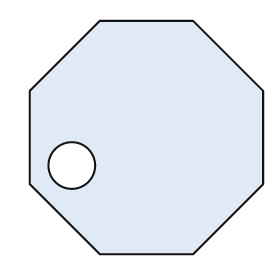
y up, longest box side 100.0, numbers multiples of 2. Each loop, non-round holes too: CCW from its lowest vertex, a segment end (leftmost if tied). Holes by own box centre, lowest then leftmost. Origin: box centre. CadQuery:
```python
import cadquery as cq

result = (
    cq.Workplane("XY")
    .moveTo(-20.0, -50.0)
    .lineTo(20.0, -50.0)
    .lineTo(50.0, -20.0)
    .lineTo(50.0, 20.0)
    .lineTo(20.0, 50.0)
    .lineTo(-20.0, 50.0)
    .lineTo(-50.0, 20.0)
    .lineTo(-50.0, -20.0)
    .close()
    .moveTo(-32.0, -12.0)
    .circle(10.0)
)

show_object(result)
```